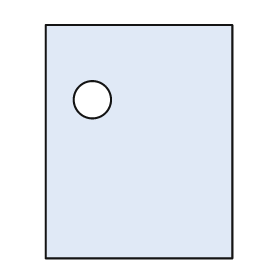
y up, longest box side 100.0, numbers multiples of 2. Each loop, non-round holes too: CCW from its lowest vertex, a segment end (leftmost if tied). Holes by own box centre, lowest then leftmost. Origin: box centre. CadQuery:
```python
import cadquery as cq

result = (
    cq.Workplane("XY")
    .moveTo(-40.0, -50.0)
    .lineTo(40.0, -50.0)
    .lineTo(40.0, 50.0)
    .lineTo(-40.0, 50.0)
    .close()
    .moveTo(-20.0, 18.0)
    .circle(8.0)
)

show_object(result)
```